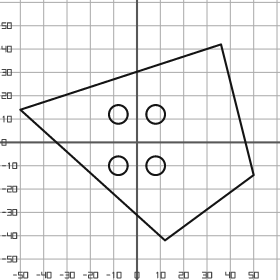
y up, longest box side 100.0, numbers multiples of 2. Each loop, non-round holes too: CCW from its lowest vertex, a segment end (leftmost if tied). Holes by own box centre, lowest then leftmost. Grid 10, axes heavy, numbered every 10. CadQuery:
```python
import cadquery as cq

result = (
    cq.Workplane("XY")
    .moveTo(12.0, -42.0)
    .lineTo(50.0, -14.0)
    .lineTo(36.0, 42.0)
    .lineTo(-50.0, 14.0)
    .close()
    .moveTo(-8.0, -10.0)
    .circle(4.0)
    .moveTo(8.0, -10.0)
    .circle(4.0)
    .moveTo(-8.0, 12.0)
    .circle(4.0)
    .moveTo(8.0, 12.0)
    .circle(4.0)
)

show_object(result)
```